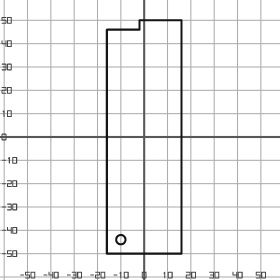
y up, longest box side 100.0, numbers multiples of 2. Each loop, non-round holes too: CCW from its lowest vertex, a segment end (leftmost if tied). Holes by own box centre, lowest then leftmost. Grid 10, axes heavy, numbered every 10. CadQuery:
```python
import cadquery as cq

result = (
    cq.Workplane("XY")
    .moveTo(-16.0, -50.0)
    .lineTo(16.0, -50.0)
    .lineTo(16.0, 50.0)
    .lineTo(-2.0, 50.0)
    .lineTo(-2.0, 46.0)
    .lineTo(-16.0, 46.0)
    .close()
    .moveTo(-10.0, -44.0)
    .circle(2.0)
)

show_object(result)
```